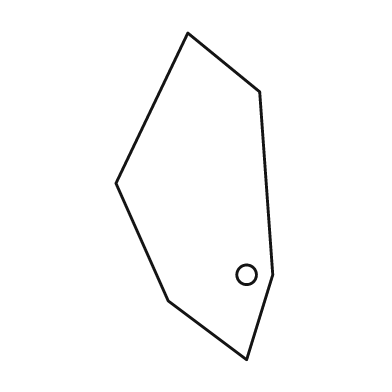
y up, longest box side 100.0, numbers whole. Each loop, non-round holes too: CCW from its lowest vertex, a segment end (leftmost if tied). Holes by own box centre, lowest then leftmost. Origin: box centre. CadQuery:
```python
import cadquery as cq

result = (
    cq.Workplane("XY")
    .moveTo(16.0, -50.0)
    .lineTo(24.0, -24.0)
    .lineTo(20.0, 32.0)
    .lineTo(-2.0, 50.0)
    .lineTo(-24.0, 4.0)
    .lineTo(-8.0, -32.0)
    .close()
    .moveTo(16.0, -24.0)
    .circle(3.0)
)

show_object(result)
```